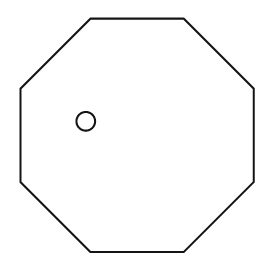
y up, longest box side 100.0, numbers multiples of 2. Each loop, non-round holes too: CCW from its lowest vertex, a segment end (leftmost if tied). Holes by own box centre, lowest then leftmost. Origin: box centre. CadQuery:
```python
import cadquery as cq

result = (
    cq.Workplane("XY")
    .moveTo(-20.0, -50.0)
    .lineTo(20.0, -50.0)
    .lineTo(50.0, -20.0)
    .lineTo(50.0, 20.0)
    .lineTo(20.0, 50.0)
    .lineTo(-20.0, 50.0)
    .lineTo(-50.0, 20.0)
    .lineTo(-50.0, -20.0)
    .close()
    .moveTo(-22.0, 6.0)
    .circle(4.0)
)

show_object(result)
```